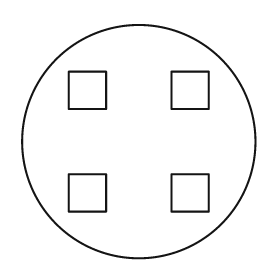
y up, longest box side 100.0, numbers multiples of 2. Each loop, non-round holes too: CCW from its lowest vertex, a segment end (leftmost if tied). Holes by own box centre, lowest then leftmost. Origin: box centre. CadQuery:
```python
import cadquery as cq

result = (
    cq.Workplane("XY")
    .moveTo(0.0, 0.0)
    .circle(50.0)
    .moveTo(-30.0, -30.0)
    .lineTo(-14.0, -30.0)
    .lineTo(-14.0, -14.0)
    .lineTo(-30.0, -14.0)
    .close()
    .moveTo(14.0, -30.0)
    .lineTo(30.0, -30.0)
    .lineTo(30.0, -14.0)
    .lineTo(14.0, -14.0)
    .close()
    .moveTo(-30.0, 14.0)
    .lineTo(-14.0, 14.0)
    .lineTo(-14.0, 30.0)
    .lineTo(-30.0, 30.0)
    .close()
    .moveTo(14.0, 14.0)
    .lineTo(30.0, 14.0)
    .lineTo(30.0, 30.0)
    .lineTo(14.0, 30.0)
    .close()
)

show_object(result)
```